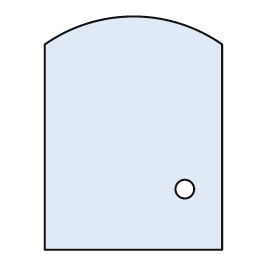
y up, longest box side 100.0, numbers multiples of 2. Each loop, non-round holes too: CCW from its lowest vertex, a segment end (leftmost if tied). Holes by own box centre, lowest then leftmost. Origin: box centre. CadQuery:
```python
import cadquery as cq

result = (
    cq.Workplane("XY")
    .moveTo(-38.0, -50.0)
    .lineTo(38.0, -50.0)
    .lineTo(38.0, 38.0)
    .threePointArc((0.0, 50.0), (-38.0, 38.0))
    .close()
    .moveTo(22.0, -24.0)
    .circle(4.0)
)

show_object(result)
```